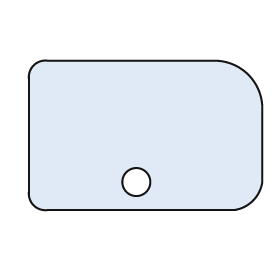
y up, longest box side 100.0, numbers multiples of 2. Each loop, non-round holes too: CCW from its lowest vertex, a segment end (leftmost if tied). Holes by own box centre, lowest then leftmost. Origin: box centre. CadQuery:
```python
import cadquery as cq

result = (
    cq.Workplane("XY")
    .moveTo(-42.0, -32.0)
    .lineTo(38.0, -32.0)
    .threePointArc((46.0, -28.0), (50.0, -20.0))
    .lineTo(50.0, 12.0)
    .threePointArc((44.0, 26.0), (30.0, 32.0))
    .lineTo(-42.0, 32.0)
    .threePointArc((-48.0, 30.0), (-50.0, 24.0))
    .lineTo(-50.0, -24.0)
    .threePointArc((-48.0, -30.0), (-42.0, -32.0))
    .close()
    .moveTo(-4.0, -20.0)
    .circle(6.0)
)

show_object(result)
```